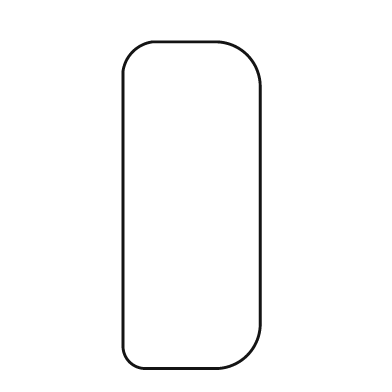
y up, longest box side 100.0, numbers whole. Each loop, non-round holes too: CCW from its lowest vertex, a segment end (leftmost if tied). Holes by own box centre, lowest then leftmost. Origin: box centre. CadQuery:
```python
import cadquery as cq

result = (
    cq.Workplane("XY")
    .moveTo(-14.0, -50.0)
    .lineTo(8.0, -50.0)
    .threePointArc((17.0, -46.0), (21.0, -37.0))
    .lineTo(21.0, 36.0)
    .threePointArc((17.0, 46.0), (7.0, 50.0))
    .lineTo(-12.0, 50.0)
    .threePointArc((-18.0, 47.0), (-21.0, 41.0))
    .lineTo(-21.0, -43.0)
    .threePointArc((-19.0, -48.0), (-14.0, -50.0))
    .close()
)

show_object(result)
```